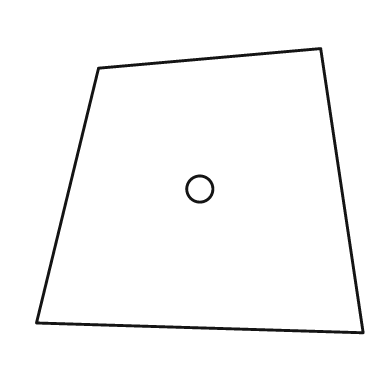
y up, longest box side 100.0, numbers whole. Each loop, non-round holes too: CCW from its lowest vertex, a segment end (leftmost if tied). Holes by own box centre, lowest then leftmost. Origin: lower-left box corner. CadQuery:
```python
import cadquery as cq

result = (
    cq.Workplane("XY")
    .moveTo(100.0, 0.0)
    .lineTo(87.0, 87.0)
    .lineTo(19.0, 81.0)
    .lineTo(0.0, 3.0)
    .close()
    .moveTo(50.0, 44.0)
    .circle(4.0)
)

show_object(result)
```